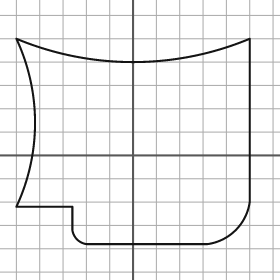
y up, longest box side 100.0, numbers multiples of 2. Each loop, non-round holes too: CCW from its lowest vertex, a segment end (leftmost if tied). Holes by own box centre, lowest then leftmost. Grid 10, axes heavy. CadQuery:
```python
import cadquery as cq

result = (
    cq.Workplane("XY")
    .moveTo(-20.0, -38.0)
    .lineTo(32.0, -38.0)
    .threePointArc((44.0, -32.0), (50.0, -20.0))
    .lineTo(50.0, 50.0)
    .threePointArc((0.0, 40.0), (-50.0, 50.0))
    .threePointArc((-42.0, 14.0), (-50.0, -22.0))
    .lineTo(-26.0, -22.0)
    .lineTo(-26.0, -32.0)
    .threePointArc((-24.0, -36.0), (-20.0, -38.0))
    .close()
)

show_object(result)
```